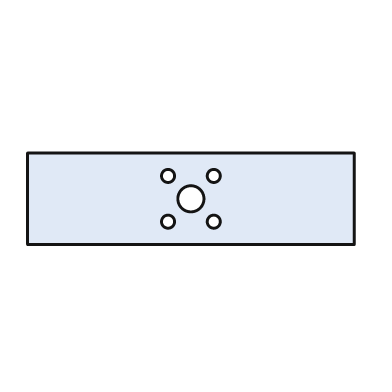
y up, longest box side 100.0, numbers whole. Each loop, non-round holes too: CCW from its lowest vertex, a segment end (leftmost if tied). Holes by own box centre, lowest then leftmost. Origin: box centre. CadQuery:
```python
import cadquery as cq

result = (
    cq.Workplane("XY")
    .moveTo(-50.0, -14.0)
    .lineTo(50.0, -14.0)
    .lineTo(50.0, 14.0)
    .lineTo(-50.0, 14.0)
    .close()
    .moveTo(-7.0, -7.0)
    .circle(2.0)
    .moveTo(7.0, -7.0)
    .circle(2.0)
    .moveTo(0.0, 0.0)
    .circle(4.0)
    .moveTo(-7.0, 7.0)
    .circle(2.0)
    .moveTo(7.0, 7.0)
    .circle(2.0)
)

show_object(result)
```